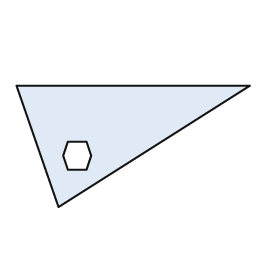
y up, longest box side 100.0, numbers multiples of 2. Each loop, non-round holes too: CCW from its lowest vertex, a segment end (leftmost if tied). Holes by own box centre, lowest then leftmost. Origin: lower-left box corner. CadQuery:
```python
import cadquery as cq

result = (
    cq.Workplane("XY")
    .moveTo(18.0, 0.0)
    .lineTo(100.0, 52.0)
    .lineTo(0.0, 52.0)
    .close()
    .moveTo(22.0, 16.0)
    .lineTo(30.0, 16.0)
    .lineTo(32.0, 22.0)
    .lineTo(30.0, 28.0)
    .lineTo(22.0, 28.0)
    .lineTo(20.0, 22.0)
    .close()
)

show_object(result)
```